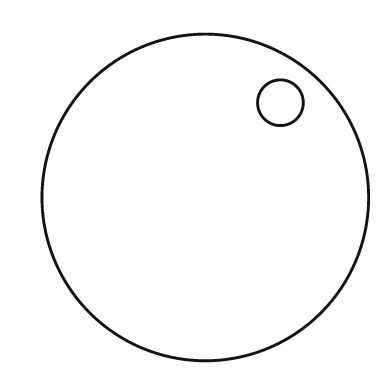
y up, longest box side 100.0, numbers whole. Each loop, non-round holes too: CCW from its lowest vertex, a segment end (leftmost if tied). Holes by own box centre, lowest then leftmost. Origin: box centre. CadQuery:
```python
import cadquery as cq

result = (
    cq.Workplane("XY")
    .moveTo(0.0, 0.0)
    .circle(50.0)
    .moveTo(23.0, 29.0)
    .circle(7.0)
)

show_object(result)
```